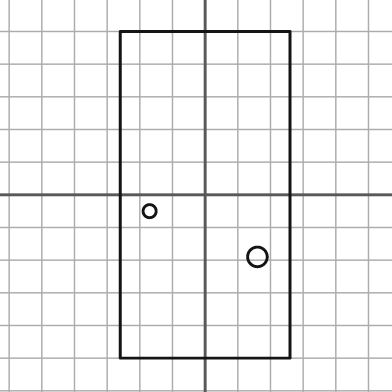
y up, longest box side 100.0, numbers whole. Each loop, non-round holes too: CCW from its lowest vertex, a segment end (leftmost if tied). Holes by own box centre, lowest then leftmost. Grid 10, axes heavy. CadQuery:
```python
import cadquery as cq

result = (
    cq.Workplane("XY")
    .moveTo(-26.0, -50.0)
    .lineTo(26.0, -50.0)
    .lineTo(26.0, 50.0)
    .lineTo(-26.0, 50.0)
    .close()
    .moveTo(16.0, -19.0)
    .circle(3.0)
    .moveTo(-17.0, -5.0)
    .circle(2.0)
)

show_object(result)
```